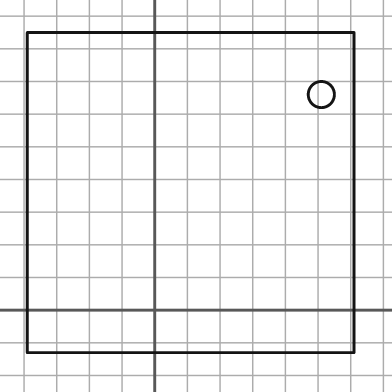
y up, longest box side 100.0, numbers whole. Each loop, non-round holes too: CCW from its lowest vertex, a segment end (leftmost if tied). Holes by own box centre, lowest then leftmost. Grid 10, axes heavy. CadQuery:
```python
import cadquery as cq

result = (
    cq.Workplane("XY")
    .moveTo(-39.0, -13.0)
    .lineTo(61.0, -13.0)
    .lineTo(61.0, 85.0)
    .lineTo(-39.0, 85.0)
    .close()
    .moveTo(51.0, 66.0)
    .circle(4.0)
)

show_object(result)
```